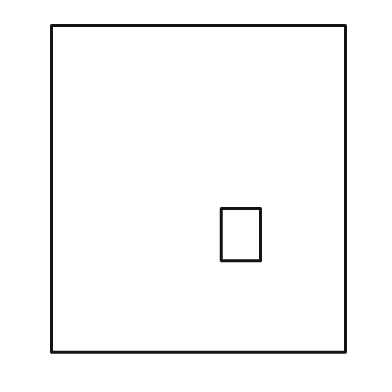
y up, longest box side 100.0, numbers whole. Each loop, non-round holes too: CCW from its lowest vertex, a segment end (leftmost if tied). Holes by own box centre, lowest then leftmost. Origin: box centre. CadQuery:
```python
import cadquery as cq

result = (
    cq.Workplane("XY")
    .moveTo(-45.0, -50.0)
    .lineTo(45.0, -50.0)
    .lineTo(45.0, 50.0)
    .lineTo(-45.0, 50.0)
    .close()
    .moveTo(7.0, -22.0)
    .lineTo(19.0, -22.0)
    .lineTo(19.0, -6.0)
    .lineTo(7.0, -6.0)
    .close()
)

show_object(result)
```